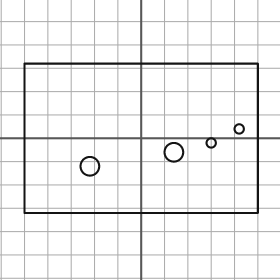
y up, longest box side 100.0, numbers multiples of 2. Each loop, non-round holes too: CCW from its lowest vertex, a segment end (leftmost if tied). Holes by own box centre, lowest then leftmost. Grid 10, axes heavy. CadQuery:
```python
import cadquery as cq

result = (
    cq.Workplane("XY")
    .moveTo(-50.0, -32.0)
    .lineTo(50.0, -32.0)
    .lineTo(50.0, 32.0)
    .lineTo(-50.0, 32.0)
    .close()
    .moveTo(-22.0, -12.0)
    .circle(4.0)
    .moveTo(14.0, -6.0)
    .circle(4.0)
    .moveTo(30.0, -2.0)
    .circle(2.0)
    .moveTo(42.0, 4.0)
    .circle(2.0)
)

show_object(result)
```